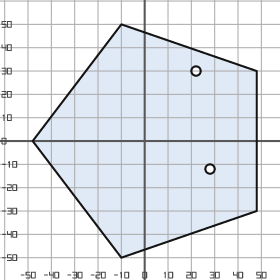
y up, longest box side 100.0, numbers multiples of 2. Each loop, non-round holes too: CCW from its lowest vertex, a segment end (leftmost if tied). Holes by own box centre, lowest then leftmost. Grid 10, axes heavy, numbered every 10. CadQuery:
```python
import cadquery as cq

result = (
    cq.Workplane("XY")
    .moveTo(-10.0, -50.0)
    .lineTo(48.0, -30.0)
    .lineTo(48.0, 30.0)
    .lineTo(-10.0, 50.0)
    .lineTo(-48.0, 0.0)
    .close()
    .moveTo(28.0, -12.0)
    .circle(2.0)
    .moveTo(22.0, 30.0)
    .circle(2.0)
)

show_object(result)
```